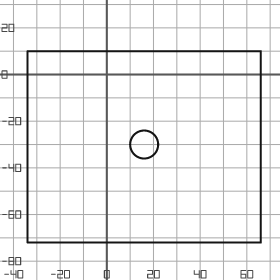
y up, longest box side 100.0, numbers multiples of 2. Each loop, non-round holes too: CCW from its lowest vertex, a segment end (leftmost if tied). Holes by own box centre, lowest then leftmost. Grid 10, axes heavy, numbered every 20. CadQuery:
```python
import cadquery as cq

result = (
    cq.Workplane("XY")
    .moveTo(-34.0, -72.0)
    .lineTo(66.0, -72.0)
    .lineTo(66.0, 10.0)
    .lineTo(-34.0, 10.0)
    .close()
    .moveTo(16.0, -30.0)
    .circle(6.0)
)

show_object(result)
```